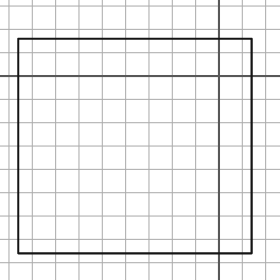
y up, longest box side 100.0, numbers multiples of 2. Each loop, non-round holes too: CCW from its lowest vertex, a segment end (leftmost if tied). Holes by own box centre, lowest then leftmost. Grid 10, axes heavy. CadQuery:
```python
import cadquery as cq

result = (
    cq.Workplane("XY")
    .moveTo(-86.0, -76.0)
    .lineTo(14.0, -76.0)
    .lineTo(14.0, 16.0)
    .lineTo(-86.0, 16.0)
    .close()
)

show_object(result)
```